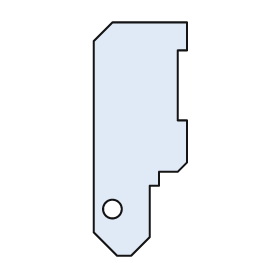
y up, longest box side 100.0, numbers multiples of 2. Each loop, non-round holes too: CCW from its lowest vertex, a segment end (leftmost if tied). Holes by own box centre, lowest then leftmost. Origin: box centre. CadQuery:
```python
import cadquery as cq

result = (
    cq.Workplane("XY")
    .moveTo(-10.0, -50.0)
    .lineTo(-4.0, -50.0)
    .lineTo(4.0, -42.0)
    .lineTo(4.0, -20.0)
    .lineTo(8.0, -20.0)
    .lineTo(8.0, -14.0)
    .lineTo(16.0, -14.0)
    .lineTo(20.0, -10.0)
    .lineTo(20.0, 8.0)
    .lineTo(16.0, 8.0)
    .lineTo(16.0, 38.0)
    .lineTo(20.0, 38.0)
    .lineTo(20.0, 50.0)
    .lineTo(-12.0, 50.0)
    .lineTo(-20.0, 42.0)
    .lineTo(-20.0, -40.0)
    .close()
    .moveTo(-12.0, -30.0)
    .circle(4.0)
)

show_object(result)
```